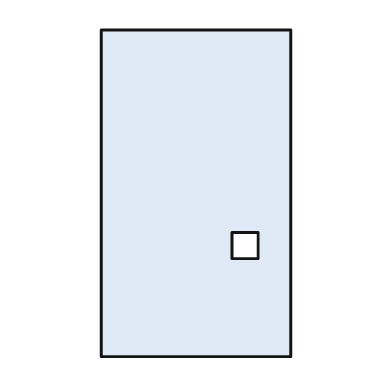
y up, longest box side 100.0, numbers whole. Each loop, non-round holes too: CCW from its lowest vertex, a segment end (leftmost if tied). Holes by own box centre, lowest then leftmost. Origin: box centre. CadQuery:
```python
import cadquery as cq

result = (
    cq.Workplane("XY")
    .moveTo(-29.0, -50.0)
    .lineTo(29.0, -50.0)
    .lineTo(29.0, 50.0)
    .lineTo(-29.0, 50.0)
    .close()
    .moveTo(11.0, -20.0)
    .lineTo(19.0, -20.0)
    .lineTo(19.0, -12.0)
    .lineTo(11.0, -12.0)
    .close()
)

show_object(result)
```